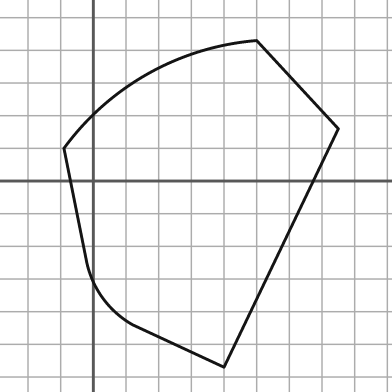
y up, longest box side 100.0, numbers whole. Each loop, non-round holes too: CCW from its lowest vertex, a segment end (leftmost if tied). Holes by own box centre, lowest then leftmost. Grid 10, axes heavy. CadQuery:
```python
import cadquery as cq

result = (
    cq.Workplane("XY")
    .moveTo(40.0, -57.0)
    .lineTo(75.0, 16.0)
    .lineTo(50.0, 43.0)
    .threePointArc((17.0, 33.0), (-9.0, 10.0))
    .lineTo(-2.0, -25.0)
    .threePointArc((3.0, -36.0), (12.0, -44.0))
    .close()
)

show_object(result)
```